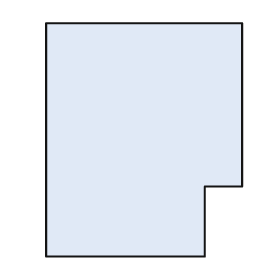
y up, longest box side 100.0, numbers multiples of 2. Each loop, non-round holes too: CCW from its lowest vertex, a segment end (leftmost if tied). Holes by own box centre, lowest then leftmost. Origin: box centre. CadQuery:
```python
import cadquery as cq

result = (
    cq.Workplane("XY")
    .moveTo(-42.0, -50.0)
    .lineTo(26.0, -50.0)
    .lineTo(26.0, -20.0)
    .lineTo(42.0, -20.0)
    .lineTo(42.0, 50.0)
    .lineTo(-42.0, 50.0)
    .close()
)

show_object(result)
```